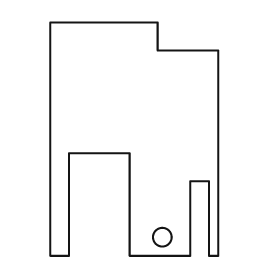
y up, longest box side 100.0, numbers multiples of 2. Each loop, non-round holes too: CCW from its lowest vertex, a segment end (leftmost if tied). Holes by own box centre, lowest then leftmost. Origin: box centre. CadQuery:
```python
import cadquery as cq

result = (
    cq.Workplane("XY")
    .moveTo(-36.0, -50.0)
    .lineTo(-28.0, -50.0)
    .lineTo(-28.0, -6.0)
    .lineTo(-2.0, -6.0)
    .lineTo(-2.0, -50.0)
    .lineTo(24.0, -50.0)
    .lineTo(24.0, -18.0)
    .lineTo(32.0, -18.0)
    .lineTo(32.0, -50.0)
    .lineTo(36.0, -50.0)
    .lineTo(36.0, 38.0)
    .lineTo(10.0, 38.0)
    .lineTo(10.0, 50.0)
    .lineTo(-36.0, 50.0)
    .close()
    .moveTo(12.0, -42.0)
    .circle(4.0)
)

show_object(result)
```